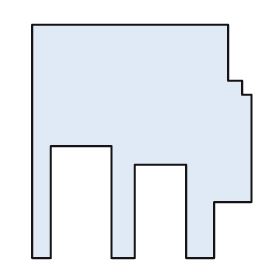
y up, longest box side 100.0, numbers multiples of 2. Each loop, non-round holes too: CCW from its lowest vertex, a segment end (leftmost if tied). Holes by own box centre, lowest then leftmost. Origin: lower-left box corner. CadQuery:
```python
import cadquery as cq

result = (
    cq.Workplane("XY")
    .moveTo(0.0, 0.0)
    .lineTo(8.0, 0.0)
    .lineTo(8.0, 48.0)
    .lineTo(34.0, 48.0)
    .lineTo(34.0, 0.0)
    .lineTo(44.0, 0.0)
    .lineTo(44.0, 40.0)
    .lineTo(66.0, 40.0)
    .lineTo(66.0, 0.0)
    .lineTo(78.0, 0.0)
    .lineTo(78.0, 24.0)
    .lineTo(94.0, 24.0)
    .lineTo(94.0, 70.0)
    .lineTo(90.0, 70.0)
    .lineTo(90.0, 76.0)
    .lineTo(84.0, 76.0)
    .lineTo(84.0, 100.0)
    .lineTo(0.0, 100.0)
    .close()
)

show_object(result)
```